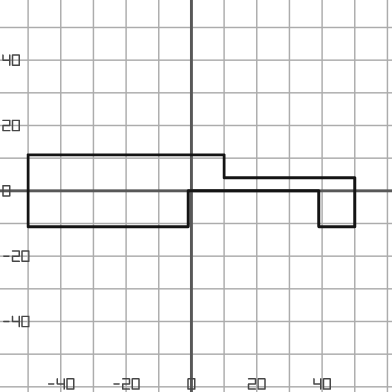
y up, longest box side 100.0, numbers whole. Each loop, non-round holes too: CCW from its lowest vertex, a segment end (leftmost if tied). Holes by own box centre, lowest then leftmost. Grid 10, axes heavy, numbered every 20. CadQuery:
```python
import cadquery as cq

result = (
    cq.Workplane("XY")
    .moveTo(-50.0, -11.0)
    .lineTo(-1.0, -11.0)
    .lineTo(-1.0, 0.0)
    .lineTo(39.0, 0.0)
    .lineTo(39.0, -11.0)
    .lineTo(50.0, -11.0)
    .lineTo(50.0, 4.0)
    .lineTo(10.0, 4.0)
    .lineTo(10.0, 11.0)
    .lineTo(-50.0, 11.0)
    .close()
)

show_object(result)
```